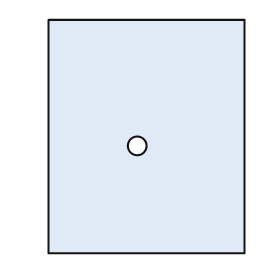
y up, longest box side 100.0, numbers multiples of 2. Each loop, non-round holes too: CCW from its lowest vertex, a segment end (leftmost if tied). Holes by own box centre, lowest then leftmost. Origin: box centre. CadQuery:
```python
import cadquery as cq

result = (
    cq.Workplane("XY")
    .moveTo(-42.0, -50.0)
    .lineTo(42.0, -50.0)
    .lineTo(42.0, 50.0)
    .lineTo(-42.0, 50.0)
    .close()
    .moveTo(-4.0, -4.0)
    .circle(4.0)
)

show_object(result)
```